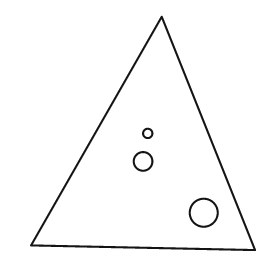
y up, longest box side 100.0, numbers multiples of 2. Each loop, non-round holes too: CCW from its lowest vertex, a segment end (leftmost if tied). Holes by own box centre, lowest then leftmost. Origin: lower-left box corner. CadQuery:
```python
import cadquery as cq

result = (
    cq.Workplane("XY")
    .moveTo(96.0, 0.0)
    .lineTo(56.0, 100.0)
    .lineTo(0.0, 2.0)
    .close()
    .moveTo(74.0, 16.0)
    .circle(6.0)
    .moveTo(48.0, 38.0)
    .circle(4.0)
    .moveTo(50.0, 50.0)
    .circle(2.0)
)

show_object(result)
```